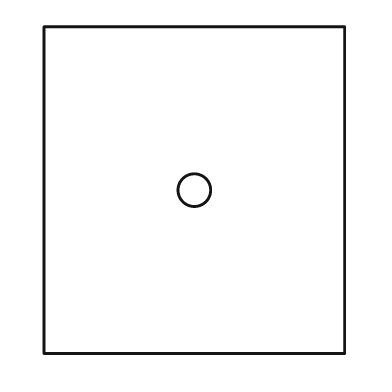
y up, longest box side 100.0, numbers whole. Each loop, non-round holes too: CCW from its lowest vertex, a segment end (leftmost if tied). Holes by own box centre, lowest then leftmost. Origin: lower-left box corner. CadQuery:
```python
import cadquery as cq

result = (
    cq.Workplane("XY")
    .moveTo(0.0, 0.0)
    .lineTo(92.0, 0.0)
    .lineTo(92.0, 100.0)
    .lineTo(0.0, 100.0)
    .close()
    .moveTo(46.0, 50.0)
    .circle(5.0)
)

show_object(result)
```